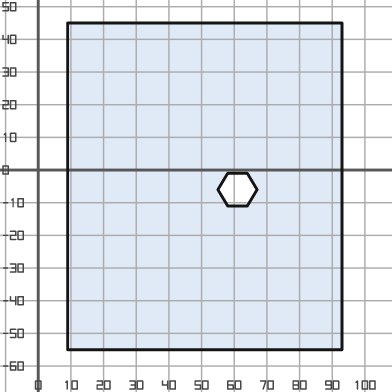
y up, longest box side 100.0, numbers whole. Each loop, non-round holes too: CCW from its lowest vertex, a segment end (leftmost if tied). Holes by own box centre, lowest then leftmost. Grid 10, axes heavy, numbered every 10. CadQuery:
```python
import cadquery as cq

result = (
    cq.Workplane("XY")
    .moveTo(9.0, -55.0)
    .lineTo(93.0, -55.0)
    .lineTo(93.0, 45.0)
    .lineTo(9.0, 45.0)
    .close()
    .moveTo(58.0, -11.0)
    .lineTo(64.0, -11.0)
    .lineTo(67.0, -6.0)
    .lineTo(64.0, -1.0)
    .lineTo(58.0, -1.0)
    .lineTo(55.0, -6.0)
    .close()
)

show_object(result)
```